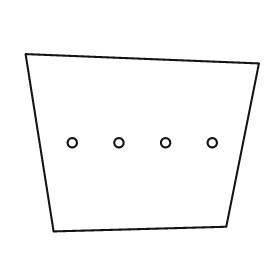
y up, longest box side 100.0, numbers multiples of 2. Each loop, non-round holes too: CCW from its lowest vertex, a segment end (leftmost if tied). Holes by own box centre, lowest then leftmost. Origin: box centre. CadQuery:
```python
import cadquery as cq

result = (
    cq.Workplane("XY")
    .moveTo(-38.0, -38.0)
    .lineTo(36.0, -36.0)
    .lineTo(50.0, 34.0)
    .lineTo(-50.0, 38.0)
    .close()
    .moveTo(-30.0, 0.0)
    .circle(2.0)
    .moveTo(-10.0, 0.0)
    .circle(2.0)
    .moveTo(10.0, 0.0)
    .circle(2.0)
    .moveTo(30.0, 0.0)
    .circle(2.0)
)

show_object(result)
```